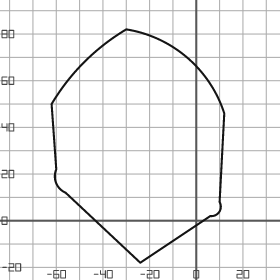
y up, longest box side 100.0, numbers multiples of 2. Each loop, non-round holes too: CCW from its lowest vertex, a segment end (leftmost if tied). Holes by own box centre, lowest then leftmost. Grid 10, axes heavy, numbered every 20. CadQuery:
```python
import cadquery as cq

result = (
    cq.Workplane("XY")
    .moveTo(-24.0, -18.0)
    .lineTo(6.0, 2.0)
    .threePointArc((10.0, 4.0), (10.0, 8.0))
    .lineTo(12.0, 46.0)
    .threePointArc((-4.0, 70.0), (-30.0, 82.0))
    .threePointArc((-48.0, 68.0), (-62.0, 50.0))
    .lineTo(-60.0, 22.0)
    .threePointArc((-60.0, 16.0), (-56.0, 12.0))
    .close()
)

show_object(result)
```